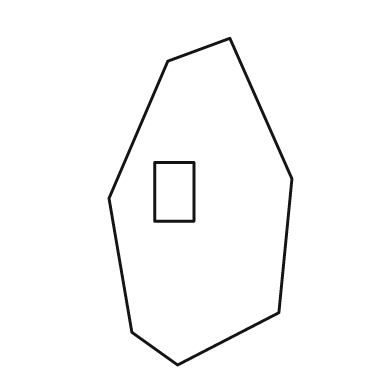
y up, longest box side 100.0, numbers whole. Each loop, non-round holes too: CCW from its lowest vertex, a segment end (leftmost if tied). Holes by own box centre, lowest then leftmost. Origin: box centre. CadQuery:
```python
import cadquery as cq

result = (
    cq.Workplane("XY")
    .moveTo(-7.0, -50.0)
    .lineTo(24.0, -34.0)
    .lineTo(28.0, 7.0)
    .lineTo(9.0, 50.0)
    .lineTo(-10.0, 43.0)
    .lineTo(-28.0, 1.0)
    .lineTo(-21.0, -40.0)
    .close()
    .moveTo(-14.0, -6.0)
    .lineTo(-2.0, -6.0)
    .lineTo(-2.0, 12.0)
    .lineTo(-14.0, 12.0)
    .close()
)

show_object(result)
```